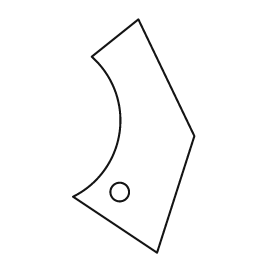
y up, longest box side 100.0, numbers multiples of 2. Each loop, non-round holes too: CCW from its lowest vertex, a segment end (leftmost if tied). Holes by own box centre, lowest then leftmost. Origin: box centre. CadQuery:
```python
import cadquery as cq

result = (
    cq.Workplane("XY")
    .moveTo(10.0, -50.0)
    .lineTo(26.0, 0.0)
    .lineTo(2.0, 50.0)
    .lineTo(-18.0, 34.0)
    .threePointArc((-6.0, 2.0), (-26.0, -26.0))
    .close()
    .moveTo(-6.0, -24.0)
    .circle(4.0)
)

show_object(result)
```